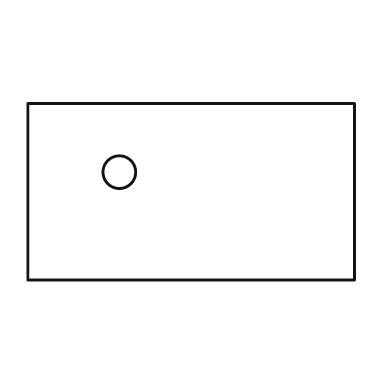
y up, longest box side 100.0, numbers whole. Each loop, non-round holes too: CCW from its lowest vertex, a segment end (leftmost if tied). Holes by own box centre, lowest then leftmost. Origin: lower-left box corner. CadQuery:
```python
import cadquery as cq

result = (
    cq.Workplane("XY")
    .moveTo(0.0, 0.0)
    .lineTo(100.0, 0.0)
    .lineTo(100.0, 54.0)
    .lineTo(0.0, 54.0)
    .close()
    .moveTo(28.0, 33.0)
    .circle(5.0)
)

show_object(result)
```